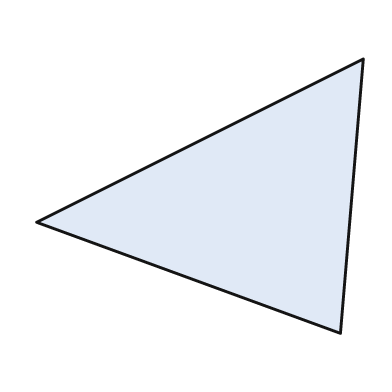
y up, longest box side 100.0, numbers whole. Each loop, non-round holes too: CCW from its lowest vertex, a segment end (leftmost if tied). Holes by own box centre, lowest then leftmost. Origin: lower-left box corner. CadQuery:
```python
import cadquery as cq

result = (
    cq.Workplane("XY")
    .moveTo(93.0, 0.0)
    .lineTo(100.0, 84.0)
    .lineTo(0.0, 34.0)
    .close()
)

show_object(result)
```